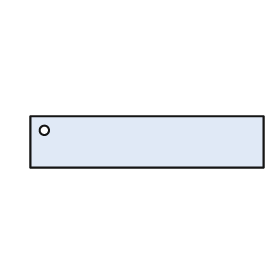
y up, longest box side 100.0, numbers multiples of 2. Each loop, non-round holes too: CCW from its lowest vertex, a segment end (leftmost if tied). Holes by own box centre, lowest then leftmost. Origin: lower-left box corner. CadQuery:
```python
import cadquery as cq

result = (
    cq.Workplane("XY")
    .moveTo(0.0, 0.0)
    .lineTo(100.0, 0.0)
    .lineTo(100.0, 22.0)
    .lineTo(0.0, 22.0)
    .close()
    .moveTo(6.0, 16.0)
    .circle(2.0)
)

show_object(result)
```